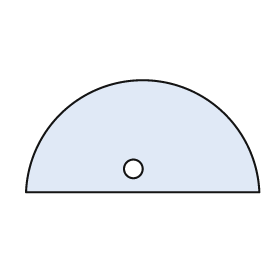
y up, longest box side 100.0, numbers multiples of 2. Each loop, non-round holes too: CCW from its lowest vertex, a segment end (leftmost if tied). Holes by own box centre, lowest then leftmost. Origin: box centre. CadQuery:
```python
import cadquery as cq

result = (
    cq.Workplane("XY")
    .moveTo(-50.0, -24.0)
    .lineTo(50.0, -24.0)
    .threePointArc((0.0, 24.0), (-50.0, -24.0))
    .close()
    .moveTo(-4.0, -14.0)
    .circle(4.0)
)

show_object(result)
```